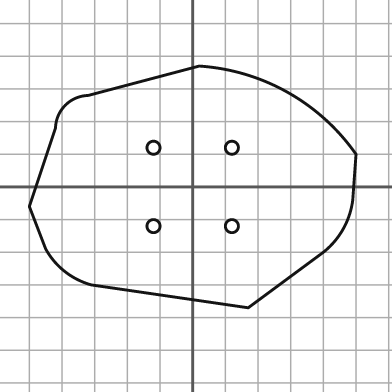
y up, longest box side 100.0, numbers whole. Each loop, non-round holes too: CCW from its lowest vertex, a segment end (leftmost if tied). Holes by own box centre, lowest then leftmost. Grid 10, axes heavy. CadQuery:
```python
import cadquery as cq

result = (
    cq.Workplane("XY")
    .moveTo(17.0, -37.0)
    .lineTo(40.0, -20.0)
    .threePointArc((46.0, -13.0), (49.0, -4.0))
    .lineTo(50.0, 10.0)
    .threePointArc((29.0, 29.0), (2.0, 37.0))
    .lineTo(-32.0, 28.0)
    .threePointArc((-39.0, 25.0), (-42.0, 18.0))
    .lineTo(-50.0, -6.0)
    .lineTo(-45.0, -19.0)
    .threePointArc((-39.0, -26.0), (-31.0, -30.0))
    .close()
    .moveTo(-12.0, -12.0)
    .circle(2.0)
    .moveTo(12.0, -12.0)
    .circle(2.0)
    .moveTo(-12.0, 12.0)
    .circle(2.0)
    .moveTo(12.0, 12.0)
    .circle(2.0)
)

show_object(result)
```